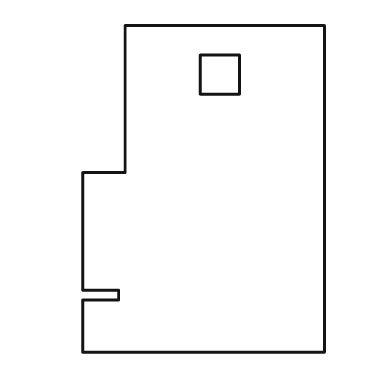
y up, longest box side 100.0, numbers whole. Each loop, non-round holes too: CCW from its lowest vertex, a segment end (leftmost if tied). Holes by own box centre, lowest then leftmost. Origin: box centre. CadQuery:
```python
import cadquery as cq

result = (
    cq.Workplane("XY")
    .moveTo(-37.0, -50.0)
    .lineTo(37.0, -50.0)
    .lineTo(37.0, 50.0)
    .lineTo(-24.0, 50.0)
    .lineTo(-24.0, 5.0)
    .lineTo(-37.0, 5.0)
    .lineTo(-37.0, -31.0)
    .lineTo(-26.0, -31.0)
    .lineTo(-26.0, -34.0)
    .lineTo(-37.0, -34.0)
    .close()
    .moveTo(-1.0, 29.0)
    .lineTo(11.0, 29.0)
    .lineTo(11.0, 41.0)
    .lineTo(-1.0, 41.0)
    .close()
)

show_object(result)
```